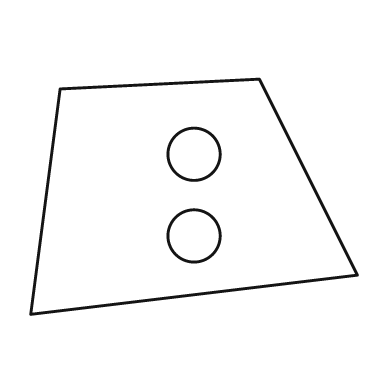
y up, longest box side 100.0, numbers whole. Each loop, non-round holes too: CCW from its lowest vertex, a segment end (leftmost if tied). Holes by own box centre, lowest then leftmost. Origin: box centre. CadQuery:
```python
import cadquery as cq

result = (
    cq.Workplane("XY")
    .moveTo(-50.0, -36.0)
    .lineTo(50.0, -24.0)
    .lineTo(20.0, 36.0)
    .lineTo(-41.0, 33.0)
    .close()
    .moveTo(0.0, -12.0)
    .circle(8.0)
    .moveTo(0.0, 13.0)
    .circle(8.0)
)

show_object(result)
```